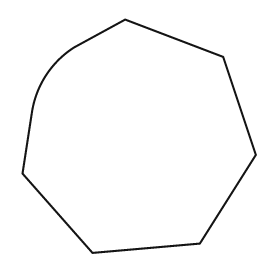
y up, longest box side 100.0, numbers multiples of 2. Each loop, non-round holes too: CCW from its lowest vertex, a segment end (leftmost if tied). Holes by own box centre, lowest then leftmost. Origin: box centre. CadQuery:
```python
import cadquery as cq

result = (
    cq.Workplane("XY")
    .moveTo(-20.0, -50.0)
    .lineTo(26.0, -46.0)
    .lineTo(50.0, -8.0)
    .lineTo(36.0, 34.0)
    .lineTo(-6.0, 50.0)
    .lineTo(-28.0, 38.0)
    .threePointArc((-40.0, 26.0), (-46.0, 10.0))
    .lineTo(-50.0, -16.0)
    .close()
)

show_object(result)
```